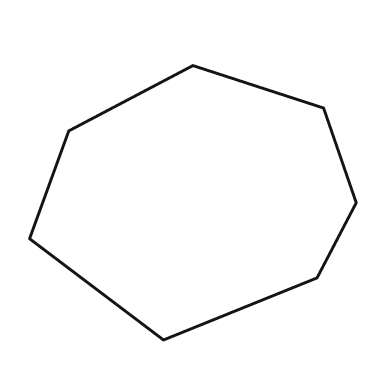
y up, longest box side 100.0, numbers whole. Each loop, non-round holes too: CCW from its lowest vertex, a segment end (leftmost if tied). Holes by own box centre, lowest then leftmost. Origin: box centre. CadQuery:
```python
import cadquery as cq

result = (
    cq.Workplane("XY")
    .moveTo(-9.0, -42.0)
    .lineTo(38.0, -23.0)
    .lineTo(50.0, 0.0)
    .lineTo(40.0, 29.0)
    .lineTo(0.0, 42.0)
    .lineTo(-38.0, 22.0)
    .lineTo(-50.0, -11.0)
    .close()
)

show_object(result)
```